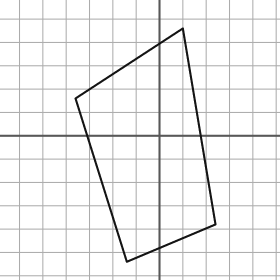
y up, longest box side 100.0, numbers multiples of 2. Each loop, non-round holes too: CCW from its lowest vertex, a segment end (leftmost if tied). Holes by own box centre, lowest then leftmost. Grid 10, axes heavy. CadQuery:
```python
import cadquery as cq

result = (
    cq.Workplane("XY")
    .moveTo(-14.0, -54.0)
    .lineTo(24.0, -38.0)
    .lineTo(10.0, 46.0)
    .lineTo(-36.0, 16.0)
    .close()
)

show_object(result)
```